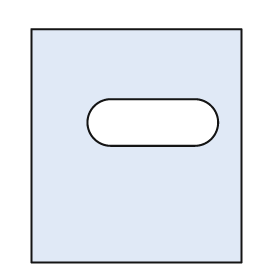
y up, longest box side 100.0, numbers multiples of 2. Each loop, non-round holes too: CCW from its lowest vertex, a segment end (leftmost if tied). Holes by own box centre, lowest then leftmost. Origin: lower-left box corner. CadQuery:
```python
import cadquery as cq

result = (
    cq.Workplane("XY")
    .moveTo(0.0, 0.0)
    .lineTo(90.0, 0.0)
    .lineTo(90.0, 100.0)
    .lineTo(0.0, 100.0)
    .close()
    .moveTo(34.0, 50.0)
    .lineTo(70.0, 50.0)
    .threePointArc((80.0, 60.0), (70.0, 70.0))
    .lineTo(34.0, 70.0)
    .threePointArc((24.0, 60.0), (34.0, 50.0))
    .close()
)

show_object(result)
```